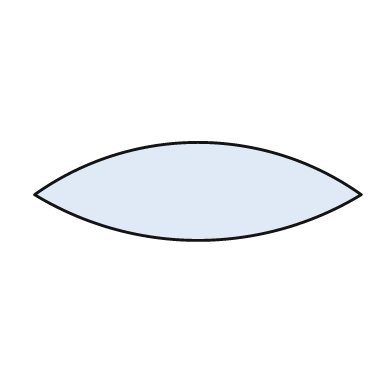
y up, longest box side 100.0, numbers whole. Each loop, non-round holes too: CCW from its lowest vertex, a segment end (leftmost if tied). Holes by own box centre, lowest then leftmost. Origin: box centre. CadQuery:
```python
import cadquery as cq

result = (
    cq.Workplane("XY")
    .moveTo(-50.0, -1.0)
    .threePointArc((0.0, -15.0), (50.0, -1.0))
    .threePointArc((0.0, 15.0), (-50.0, -1.0))
    .close()
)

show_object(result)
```